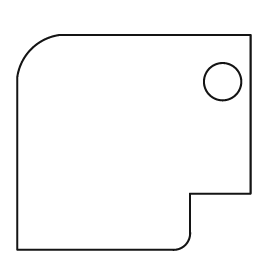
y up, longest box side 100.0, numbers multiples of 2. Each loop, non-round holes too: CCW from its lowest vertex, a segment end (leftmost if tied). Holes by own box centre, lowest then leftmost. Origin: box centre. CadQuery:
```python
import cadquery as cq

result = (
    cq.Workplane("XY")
    .moveTo(-50.0, -46.0)
    .lineTo(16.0, -46.0)
    .threePointArc((22.0, -44.0), (24.0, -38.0))
    .lineTo(24.0, -22.0)
    .lineTo(50.0, -22.0)
    .lineTo(50.0, 46.0)
    .lineTo(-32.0, 46.0)
    .threePointArc((-44.0, 40.0), (-50.0, 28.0))
    .close()
    .moveTo(38.0, 26.0)
    .circle(8.0)
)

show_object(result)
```